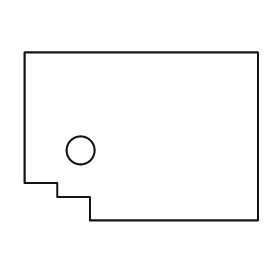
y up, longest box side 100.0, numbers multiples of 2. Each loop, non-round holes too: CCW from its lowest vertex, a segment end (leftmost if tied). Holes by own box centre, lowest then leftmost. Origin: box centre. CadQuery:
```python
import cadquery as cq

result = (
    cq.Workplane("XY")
    .moveTo(-22.0, -36.0)
    .lineTo(50.0, -36.0)
    .lineTo(50.0, 36.0)
    .lineTo(-50.0, 36.0)
    .lineTo(-50.0, -20.0)
    .lineTo(-36.0, -20.0)
    .lineTo(-36.0, -26.0)
    .lineTo(-22.0, -26.0)
    .close()
    .moveTo(-26.0, -6.0)
    .circle(6.0)
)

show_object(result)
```